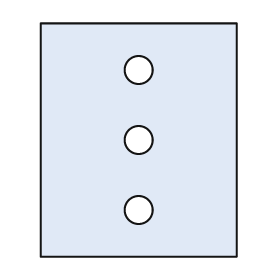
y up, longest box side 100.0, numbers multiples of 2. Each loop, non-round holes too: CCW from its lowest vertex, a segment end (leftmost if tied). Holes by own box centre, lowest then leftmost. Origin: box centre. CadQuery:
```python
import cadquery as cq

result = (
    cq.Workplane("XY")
    .moveTo(-42.0, -50.0)
    .lineTo(42.0, -50.0)
    .lineTo(42.0, 50.0)
    .lineTo(-42.0, 50.0)
    .close()
    .moveTo(0.0, -30.0)
    .circle(6.0)
    .moveTo(0.0, 0.0)
    .circle(6.0)
    .moveTo(0.0, 30.0)
    .circle(6.0)
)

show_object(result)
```